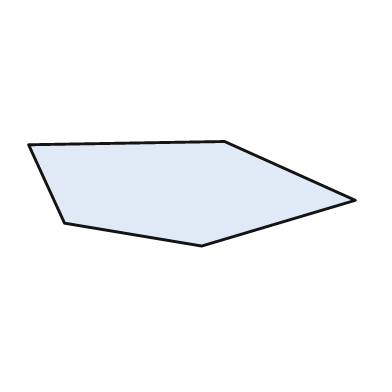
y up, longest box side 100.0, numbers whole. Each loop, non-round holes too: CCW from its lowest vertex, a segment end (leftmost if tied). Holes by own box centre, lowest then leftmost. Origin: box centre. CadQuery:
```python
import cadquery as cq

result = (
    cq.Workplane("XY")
    .moveTo(3.0, -16.0)
    .lineTo(50.0, -2.0)
    .lineTo(10.0, 16.0)
    .lineTo(-50.0, 15.0)
    .lineTo(-39.0, -9.0)
    .close()
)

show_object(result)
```